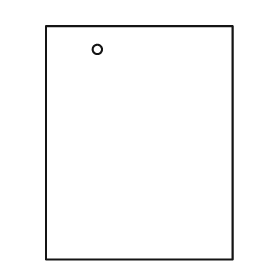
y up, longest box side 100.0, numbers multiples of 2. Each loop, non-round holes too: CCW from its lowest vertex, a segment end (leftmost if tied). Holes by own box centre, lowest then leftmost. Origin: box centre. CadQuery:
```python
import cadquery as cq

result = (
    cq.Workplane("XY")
    .moveTo(-40.0, -50.0)
    .lineTo(40.0, -50.0)
    .lineTo(40.0, 50.0)
    .lineTo(-40.0, 50.0)
    .close()
    .moveTo(-18.0, 40.0)
    .circle(2.0)
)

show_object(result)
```